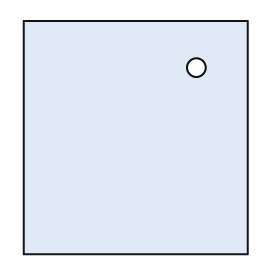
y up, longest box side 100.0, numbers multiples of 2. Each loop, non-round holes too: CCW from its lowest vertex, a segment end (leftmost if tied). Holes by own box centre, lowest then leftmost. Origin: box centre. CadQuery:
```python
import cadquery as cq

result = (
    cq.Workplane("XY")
    .moveTo(-48.0, -50.0)
    .lineTo(48.0, -50.0)
    .lineTo(48.0, 50.0)
    .lineTo(-48.0, 50.0)
    .close()
    .moveTo(26.0, 30.0)
    .circle(4.0)
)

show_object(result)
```